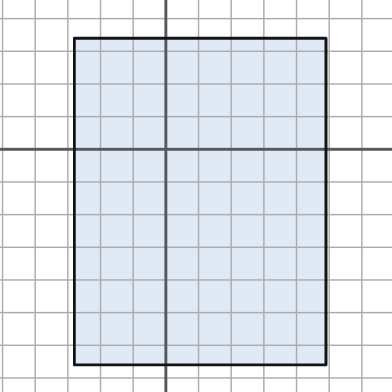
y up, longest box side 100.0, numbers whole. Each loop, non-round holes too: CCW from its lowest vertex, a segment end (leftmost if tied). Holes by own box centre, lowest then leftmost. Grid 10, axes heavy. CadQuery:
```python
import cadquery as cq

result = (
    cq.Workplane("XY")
    .moveTo(-28.0, -66.0)
    .lineTo(49.0, -66.0)
    .lineTo(49.0, 34.0)
    .lineTo(-28.0, 34.0)
    .close()
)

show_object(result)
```